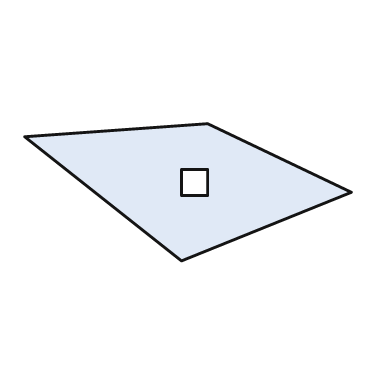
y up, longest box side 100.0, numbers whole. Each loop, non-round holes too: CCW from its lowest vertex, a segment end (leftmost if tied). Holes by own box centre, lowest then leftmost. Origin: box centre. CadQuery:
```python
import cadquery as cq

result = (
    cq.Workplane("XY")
    .moveTo(-2.0, -21.0)
    .lineTo(50.0, 0.0)
    .lineTo(6.0, 21.0)
    .lineTo(-50.0, 17.0)
    .close()
    .moveTo(-2.0, -1.0)
    .lineTo(6.0, -1.0)
    .lineTo(6.0, 7.0)
    .lineTo(-2.0, 7.0)
    .close()
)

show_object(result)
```